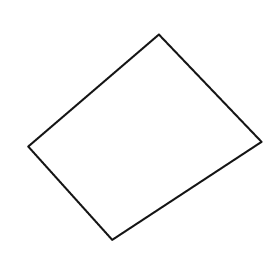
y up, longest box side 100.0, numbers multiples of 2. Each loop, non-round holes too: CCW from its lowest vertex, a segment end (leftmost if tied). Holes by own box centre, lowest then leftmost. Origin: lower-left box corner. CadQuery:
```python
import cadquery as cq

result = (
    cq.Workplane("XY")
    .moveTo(36.0, 0.0)
    .lineTo(100.0, 42.0)
    .lineTo(56.0, 88.0)
    .lineTo(0.0, 40.0)
    .close()
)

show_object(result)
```